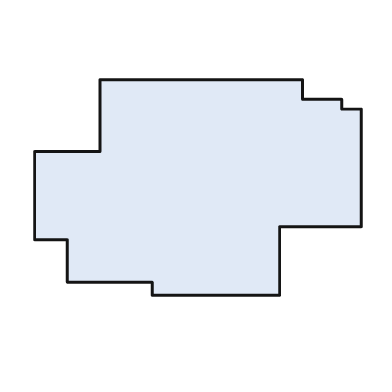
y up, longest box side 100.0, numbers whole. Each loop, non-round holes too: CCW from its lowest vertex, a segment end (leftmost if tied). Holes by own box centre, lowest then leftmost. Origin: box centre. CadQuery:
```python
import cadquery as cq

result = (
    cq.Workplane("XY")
    .moveTo(-14.0, -33.0)
    .lineTo(25.0, -33.0)
    .lineTo(25.0, -12.0)
    .lineTo(50.0, -12.0)
    .lineTo(50.0, 24.0)
    .lineTo(44.0, 24.0)
    .lineTo(44.0, 27.0)
    .lineTo(32.0, 27.0)
    .lineTo(32.0, 33.0)
    .lineTo(-30.0, 33.0)
    .lineTo(-30.0, 11.0)
    .lineTo(-50.0, 11.0)
    .lineTo(-50.0, -16.0)
    .lineTo(-40.0, -16.0)
    .lineTo(-40.0, -29.0)
    .lineTo(-14.0, -29.0)
    .close()
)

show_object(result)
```